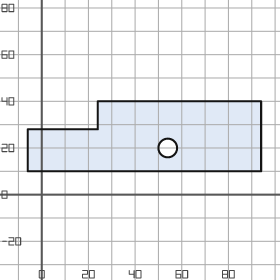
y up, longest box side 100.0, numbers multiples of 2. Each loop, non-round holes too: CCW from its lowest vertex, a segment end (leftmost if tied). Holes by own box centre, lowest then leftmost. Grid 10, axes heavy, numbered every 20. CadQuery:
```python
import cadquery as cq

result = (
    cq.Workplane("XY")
    .moveTo(-6.0, 10.0)
    .lineTo(94.0, 10.0)
    .lineTo(94.0, 40.0)
    .lineTo(24.0, 40.0)
    .lineTo(24.0, 28.0)
    .lineTo(-6.0, 28.0)
    .close()
    .moveTo(54.0, 20.0)
    .circle(4.0)
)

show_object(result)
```